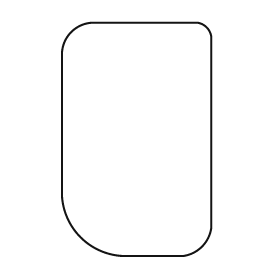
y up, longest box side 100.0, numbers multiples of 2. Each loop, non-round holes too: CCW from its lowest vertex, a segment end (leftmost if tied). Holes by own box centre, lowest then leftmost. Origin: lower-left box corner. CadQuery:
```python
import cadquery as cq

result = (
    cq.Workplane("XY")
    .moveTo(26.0, 0.0)
    .lineTo(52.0, 0.0)
    .threePointArc((60.0, 4.0), (64.0, 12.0))
    .lineTo(64.0, 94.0)
    .threePointArc((62.0, 98.0), (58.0, 100.0))
    .lineTo(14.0, 100.0)
    .threePointArc((4.0, 96.0), (0.0, 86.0))
    .lineTo(0.0, 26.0)
    .threePointArc((8.0, 8.0), (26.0, 0.0))
    .close()
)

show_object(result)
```